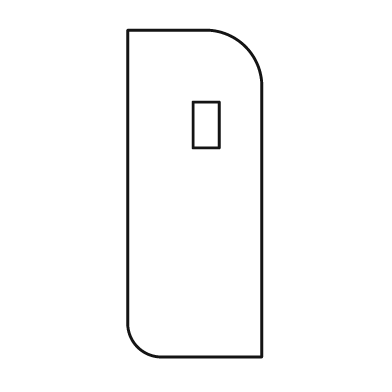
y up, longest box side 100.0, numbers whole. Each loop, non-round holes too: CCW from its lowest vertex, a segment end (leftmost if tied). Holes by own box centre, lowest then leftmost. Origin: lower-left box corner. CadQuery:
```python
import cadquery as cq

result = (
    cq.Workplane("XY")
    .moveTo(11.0, 0.0)
    .lineTo(41.0, 0.0)
    .lineTo(41.0, 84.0)
    .threePointArc((36.0, 95.0), (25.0, 100.0))
    .lineTo(0.0, 100.0)
    .lineTo(0.0, 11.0)
    .threePointArc((3.0, 3.0), (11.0, 0.0))
    .close()
    .moveTo(20.0, 64.0)
    .lineTo(28.0, 64.0)
    .lineTo(28.0, 78.0)
    .lineTo(20.0, 78.0)
    .close()
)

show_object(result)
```